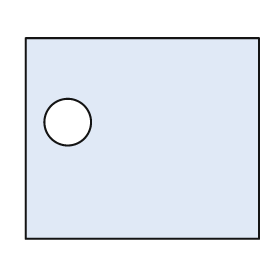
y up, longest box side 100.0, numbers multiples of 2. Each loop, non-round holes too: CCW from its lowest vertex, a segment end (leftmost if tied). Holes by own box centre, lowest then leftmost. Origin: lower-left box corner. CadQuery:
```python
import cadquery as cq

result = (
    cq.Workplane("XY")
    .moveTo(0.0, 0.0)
    .lineTo(100.0, 0.0)
    .lineTo(100.0, 86.0)
    .lineTo(0.0, 86.0)
    .close()
    .moveTo(18.0, 50.0)
    .circle(10.0)
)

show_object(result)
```